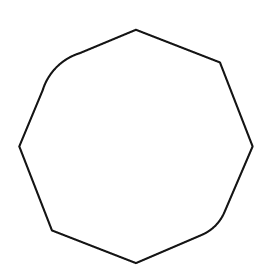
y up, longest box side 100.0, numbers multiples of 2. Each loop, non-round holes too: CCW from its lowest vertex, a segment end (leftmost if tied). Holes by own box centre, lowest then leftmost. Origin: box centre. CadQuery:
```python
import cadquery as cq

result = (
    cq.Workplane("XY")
    .moveTo(0.0, -50.0)
    .lineTo(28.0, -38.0)
    .threePointArc((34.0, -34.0), (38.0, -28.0))
    .lineTo(50.0, 0.0)
    .lineTo(36.0, 36.0)
    .lineTo(0.0, 50.0)
    .lineTo(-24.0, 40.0)
    .threePointArc((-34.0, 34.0), (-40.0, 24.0))
    .lineTo(-50.0, 0.0)
    .lineTo(-36.0, -36.0)
    .close()
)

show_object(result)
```